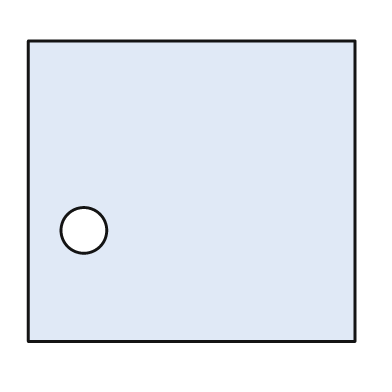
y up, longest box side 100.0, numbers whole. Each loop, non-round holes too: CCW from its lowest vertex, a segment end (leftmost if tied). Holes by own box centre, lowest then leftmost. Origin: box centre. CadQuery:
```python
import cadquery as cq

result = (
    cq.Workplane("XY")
    .moveTo(-50.0, -46.0)
    .lineTo(50.0, -46.0)
    .lineTo(50.0, 46.0)
    .lineTo(-50.0, 46.0)
    .close()
    .moveTo(-33.0, -12.0)
    .circle(7.0)
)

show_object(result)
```